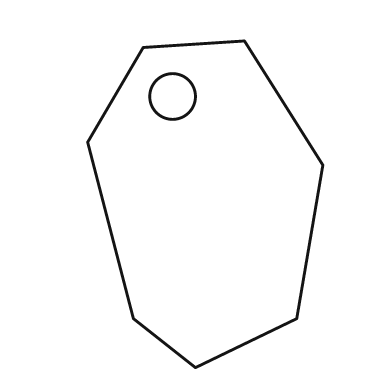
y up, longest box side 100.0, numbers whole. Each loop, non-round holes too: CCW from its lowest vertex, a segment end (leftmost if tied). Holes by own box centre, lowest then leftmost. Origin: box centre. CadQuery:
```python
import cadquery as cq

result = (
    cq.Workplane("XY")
    .moveTo(-3.0, -50.0)
    .lineTo(28.0, -35.0)
    .lineTo(36.0, 12.0)
    .lineTo(12.0, 50.0)
    .lineTo(-19.0, 48.0)
    .lineTo(-36.0, 19.0)
    .lineTo(-22.0, -35.0)
    .close()
    .moveTo(-10.0, 33.0)
    .circle(7.0)
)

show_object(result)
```